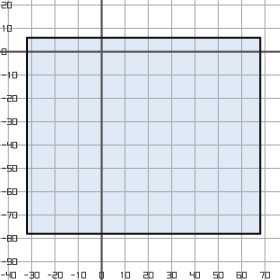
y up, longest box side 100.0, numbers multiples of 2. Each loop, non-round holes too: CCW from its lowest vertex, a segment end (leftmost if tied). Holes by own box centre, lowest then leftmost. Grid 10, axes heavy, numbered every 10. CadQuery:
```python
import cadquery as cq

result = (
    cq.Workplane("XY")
    .moveTo(-32.0, -78.0)
    .lineTo(68.0, -78.0)
    .lineTo(68.0, 6.0)
    .lineTo(-32.0, 6.0)
    .close()
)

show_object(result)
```